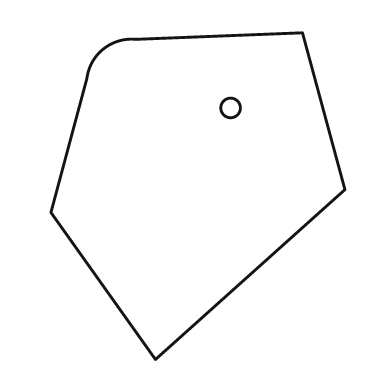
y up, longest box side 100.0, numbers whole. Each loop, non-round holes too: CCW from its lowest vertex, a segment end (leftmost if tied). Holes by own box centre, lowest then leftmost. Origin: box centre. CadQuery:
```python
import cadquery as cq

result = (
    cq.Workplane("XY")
    .moveTo(-13.0, -50.0)
    .lineTo(45.0, 2.0)
    .lineTo(32.0, 50.0)
    .lineTo(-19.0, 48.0)
    .threePointArc((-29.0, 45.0), (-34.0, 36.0))
    .lineTo(-45.0, -5.0)
    .close()
    .moveTo(10.0, 27.0)
    .circle(3.0)
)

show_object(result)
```